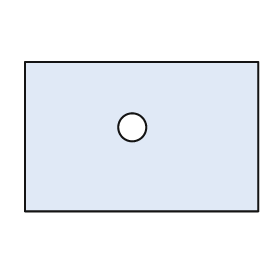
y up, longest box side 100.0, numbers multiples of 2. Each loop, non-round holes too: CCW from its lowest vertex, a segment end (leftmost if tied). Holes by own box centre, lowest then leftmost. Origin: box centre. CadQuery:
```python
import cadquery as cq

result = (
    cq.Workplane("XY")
    .moveTo(-50.0, -32.0)
    .lineTo(50.0, -32.0)
    .lineTo(50.0, 32.0)
    .lineTo(-50.0, 32.0)
    .close()
    .moveTo(-4.0, 4.0)
    .circle(6.0)
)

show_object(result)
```